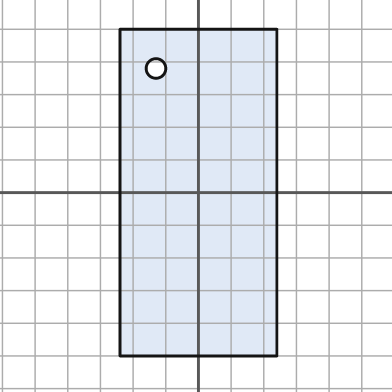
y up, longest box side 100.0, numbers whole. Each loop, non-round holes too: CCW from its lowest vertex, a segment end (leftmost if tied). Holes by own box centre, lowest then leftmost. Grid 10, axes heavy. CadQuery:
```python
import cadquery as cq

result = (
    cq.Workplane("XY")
    .moveTo(-24.0, -50.0)
    .lineTo(24.0, -50.0)
    .lineTo(24.0, 50.0)
    .lineTo(-24.0, 50.0)
    .close()
    .moveTo(-13.0, 38.0)
    .circle(3.0)
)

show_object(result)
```